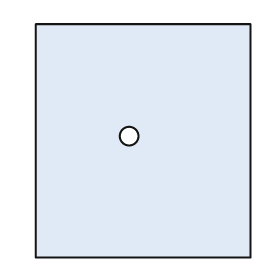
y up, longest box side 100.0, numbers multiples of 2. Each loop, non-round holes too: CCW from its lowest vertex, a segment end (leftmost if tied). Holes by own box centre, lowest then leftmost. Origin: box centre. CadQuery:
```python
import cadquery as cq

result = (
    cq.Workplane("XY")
    .moveTo(-46.0, -50.0)
    .lineTo(46.0, -50.0)
    .lineTo(46.0, 50.0)
    .lineTo(-46.0, 50.0)
    .close()
    .moveTo(-6.0, 2.0)
    .circle(4.0)
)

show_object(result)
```